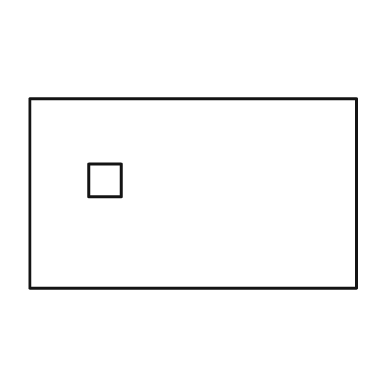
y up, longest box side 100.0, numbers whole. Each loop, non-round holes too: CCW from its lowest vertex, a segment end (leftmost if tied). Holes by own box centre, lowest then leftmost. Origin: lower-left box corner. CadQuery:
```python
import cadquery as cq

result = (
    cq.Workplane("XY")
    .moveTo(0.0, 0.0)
    .lineTo(100.0, 0.0)
    .lineTo(100.0, 58.0)
    .lineTo(0.0, 58.0)
    .close()
    .moveTo(18.0, 28.0)
    .lineTo(28.0, 28.0)
    .lineTo(28.0, 38.0)
    .lineTo(18.0, 38.0)
    .close()
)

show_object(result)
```